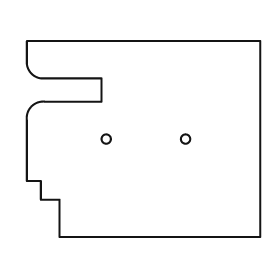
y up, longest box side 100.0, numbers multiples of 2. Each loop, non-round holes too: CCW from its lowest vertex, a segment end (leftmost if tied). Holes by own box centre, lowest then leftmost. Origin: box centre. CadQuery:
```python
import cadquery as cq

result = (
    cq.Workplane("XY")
    .moveTo(-36.0, -42.0)
    .lineTo(50.0, -42.0)
    .lineTo(50.0, 42.0)
    .lineTo(-50.0, 42.0)
    .lineTo(-50.0, 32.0)
    .threePointArc((-48.0, 28.0), (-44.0, 26.0))
    .lineTo(-18.0, 26.0)
    .lineTo(-18.0, 16.0)
    .lineTo(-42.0, 16.0)
    .threePointArc((-48.0, 14.0), (-50.0, 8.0))
    .lineTo(-50.0, -18.0)
    .lineTo(-44.0, -18.0)
    .lineTo(-44.0, -26.0)
    .lineTo(-36.0, -26.0)
    .close()
    .moveTo(-16.0, 0.0)
    .circle(2.0)
    .moveTo(18.0, 0.0)
    .circle(2.0)
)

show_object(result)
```